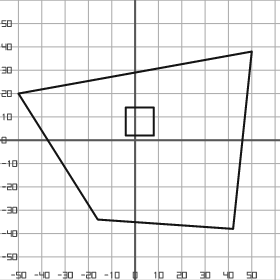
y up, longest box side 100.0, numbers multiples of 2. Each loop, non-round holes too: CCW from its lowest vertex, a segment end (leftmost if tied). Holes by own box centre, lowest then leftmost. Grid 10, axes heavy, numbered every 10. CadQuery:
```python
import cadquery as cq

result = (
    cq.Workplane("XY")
    .moveTo(42.0, -38.0)
    .lineTo(50.0, 38.0)
    .lineTo(-50.0, 20.0)
    .lineTo(-16.0, -34.0)
    .close()
    .moveTo(-4.0, 2.0)
    .lineTo(8.0, 2.0)
    .lineTo(8.0, 14.0)
    .lineTo(-4.0, 14.0)
    .close()
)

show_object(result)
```